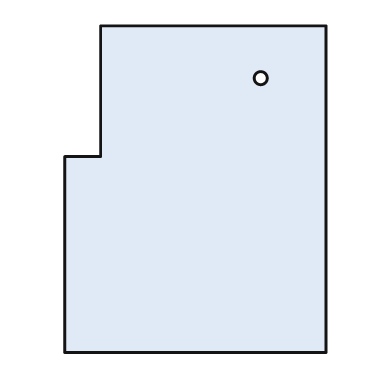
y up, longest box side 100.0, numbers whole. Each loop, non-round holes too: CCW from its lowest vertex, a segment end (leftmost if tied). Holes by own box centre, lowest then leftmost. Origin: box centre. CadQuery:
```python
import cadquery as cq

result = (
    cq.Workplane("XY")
    .moveTo(-40.0, -50.0)
    .lineTo(40.0, -50.0)
    .lineTo(40.0, 50.0)
    .lineTo(-29.0, 50.0)
    .lineTo(-29.0, 10.0)
    .lineTo(-40.0, 10.0)
    .close()
    .moveTo(20.0, 34.0)
    .circle(2.0)
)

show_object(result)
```